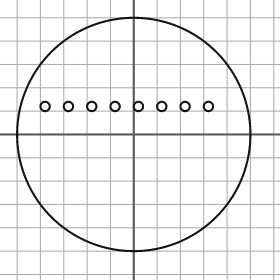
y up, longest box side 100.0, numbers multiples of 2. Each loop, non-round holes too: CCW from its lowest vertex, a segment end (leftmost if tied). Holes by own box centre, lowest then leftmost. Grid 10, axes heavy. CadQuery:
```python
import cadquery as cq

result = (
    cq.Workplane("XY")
    .moveTo(0.0, 0.0)
    .circle(50.0)
    .moveTo(-38.0, 12.0)
    .circle(2.0)
    .moveTo(-28.0, 12.0)
    .circle(2.0)
    .moveTo(-18.0, 12.0)
    .circle(2.0)
    .moveTo(-8.0, 12.0)
    .circle(2.0)
    .moveTo(2.0, 12.0)
    .circle(2.0)
    .moveTo(12.0, 12.0)
    .circle(2.0)
    .moveTo(22.0, 12.0)
    .circle(2.0)
    .moveTo(32.0, 12.0)
    .circle(2.0)
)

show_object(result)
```